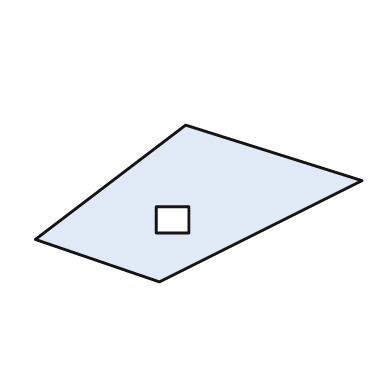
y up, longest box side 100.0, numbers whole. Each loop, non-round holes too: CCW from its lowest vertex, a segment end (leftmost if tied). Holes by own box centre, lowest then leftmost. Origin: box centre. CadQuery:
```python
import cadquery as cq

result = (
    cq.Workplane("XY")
    .moveTo(-12.0, -24.0)
    .lineTo(50.0, 7.0)
    .lineTo(-4.0, 24.0)
    .lineTo(-50.0, -11.0)
    .close()
    .moveTo(-13.0, -9.0)
    .lineTo(-3.0, -9.0)
    .lineTo(-3.0, -1.0)
    .lineTo(-13.0, -1.0)
    .close()
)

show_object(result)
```